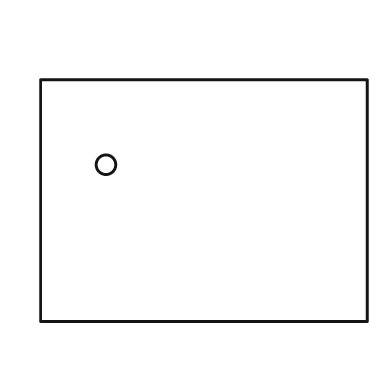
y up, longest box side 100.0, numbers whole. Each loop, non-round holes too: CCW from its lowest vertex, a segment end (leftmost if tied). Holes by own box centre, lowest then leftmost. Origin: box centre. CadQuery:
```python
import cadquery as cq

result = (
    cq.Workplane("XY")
    .moveTo(-50.0, -37.0)
    .lineTo(50.0, -37.0)
    .lineTo(50.0, 37.0)
    .lineTo(-50.0, 37.0)
    .close()
    .moveTo(-30.0, 11.0)
    .circle(3.0)
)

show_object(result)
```